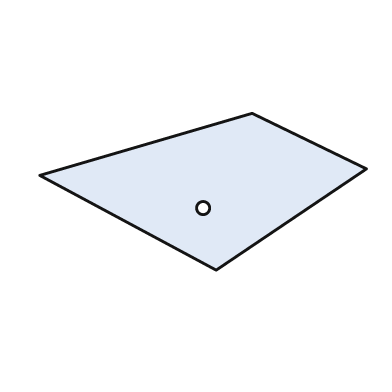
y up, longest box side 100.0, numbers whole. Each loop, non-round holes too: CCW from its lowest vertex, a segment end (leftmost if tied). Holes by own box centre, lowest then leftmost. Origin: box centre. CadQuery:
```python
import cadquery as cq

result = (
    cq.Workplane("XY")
    .moveTo(4.0, -24.0)
    .lineTo(50.0, 7.0)
    .lineTo(15.0, 24.0)
    .lineTo(-50.0, 5.0)
    .close()
    .moveTo(0.0, -5.0)
    .circle(2.0)
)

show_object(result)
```